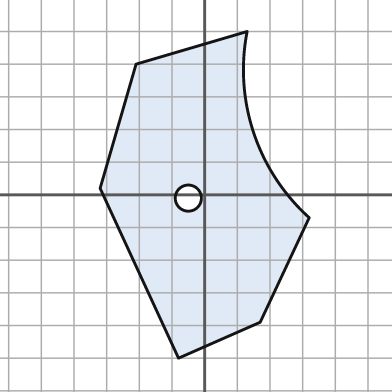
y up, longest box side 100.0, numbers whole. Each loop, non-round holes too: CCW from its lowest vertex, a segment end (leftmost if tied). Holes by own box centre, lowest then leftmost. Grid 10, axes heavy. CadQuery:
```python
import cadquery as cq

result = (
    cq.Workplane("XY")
    .moveTo(-8.0, -50.0)
    .lineTo(17.0, -39.0)
    .lineTo(32.0, -7.0)
    .threePointArc((15.0, 19.0), (13.0, 50.0))
    .lineTo(-21.0, 40.0)
    .lineTo(-32.0, 2.0)
    .close()
    .moveTo(-5.0, -1.0)
    .circle(4.0)
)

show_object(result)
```